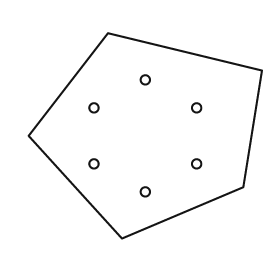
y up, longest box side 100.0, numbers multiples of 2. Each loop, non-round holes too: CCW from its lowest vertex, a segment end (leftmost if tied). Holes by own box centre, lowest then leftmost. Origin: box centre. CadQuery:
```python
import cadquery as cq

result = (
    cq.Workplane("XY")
    .moveTo(-10.0, -44.0)
    .lineTo(42.0, -22.0)
    .lineTo(50.0, 28.0)
    .lineTo(-16.0, 44.0)
    .lineTo(-50.0, 0.0)
    .close()
    .moveTo(0.0, -24.0)
    .circle(2.0)
    .moveTo(-22.0, -12.0)
    .circle(2.0)
    .moveTo(22.0, -12.0)
    .circle(2.0)
    .moveTo(-22.0, 12.0)
    .circle(2.0)
    .moveTo(22.0, 12.0)
    .circle(2.0)
    .moveTo(0.0, 24.0)
    .circle(2.0)
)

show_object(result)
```